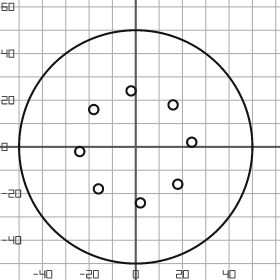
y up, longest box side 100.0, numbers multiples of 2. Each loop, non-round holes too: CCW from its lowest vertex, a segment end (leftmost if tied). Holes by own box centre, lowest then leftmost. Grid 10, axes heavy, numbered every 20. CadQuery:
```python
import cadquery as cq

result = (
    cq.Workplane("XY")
    .moveTo(0.0, 0.0)
    .circle(50.0)
    .moveTo(2.0, -24.0)
    .circle(2.0)
    .moveTo(-16.0, -18.0)
    .circle(2.0)
    .moveTo(18.0, -16.0)
    .circle(2.0)
    .moveTo(-24.0, -2.0)
    .circle(2.0)
    .moveTo(24.0, 2.0)
    .circle(2.0)
    .moveTo(-18.0, 16.0)
    .circle(2.0)
    .moveTo(16.0, 18.0)
    .circle(2.0)
    .moveTo(-2.0, 24.0)
    .circle(2.0)
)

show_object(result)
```